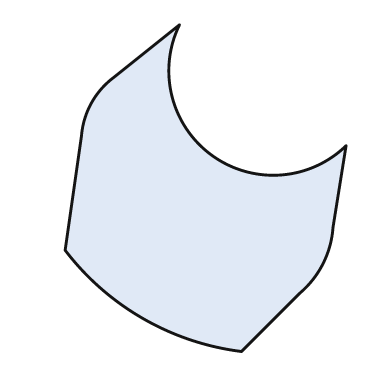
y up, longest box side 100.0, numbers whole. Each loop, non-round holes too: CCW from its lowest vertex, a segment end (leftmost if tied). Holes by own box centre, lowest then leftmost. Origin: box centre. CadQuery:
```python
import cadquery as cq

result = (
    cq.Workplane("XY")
    .moveTo(11.0, -50.0)
    .lineTo(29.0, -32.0)
    .threePointArc((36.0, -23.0), (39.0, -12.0))
    .lineTo(43.0, 13.0)
    .threePointArc((2.0, 10.0), (-8.0, 50.0))
    .lineTo(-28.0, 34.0)
    .threePointArc((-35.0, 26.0), (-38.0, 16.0))
    .lineTo(-43.0, -19.0)
    .threePointArc((-19.0, -40.0), (11.0, -50.0))
    .close()
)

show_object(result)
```